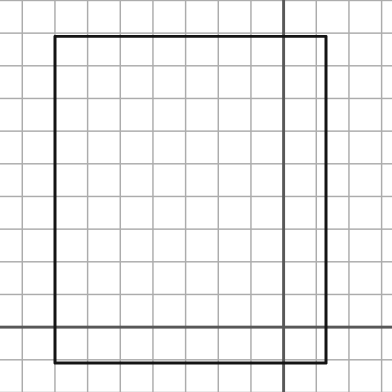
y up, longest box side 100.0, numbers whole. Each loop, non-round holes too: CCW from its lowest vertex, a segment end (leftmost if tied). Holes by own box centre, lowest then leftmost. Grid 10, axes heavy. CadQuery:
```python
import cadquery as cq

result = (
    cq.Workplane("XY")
    .moveTo(-70.0, -11.0)
    .lineTo(13.0, -11.0)
    .lineTo(13.0, 89.0)
    .lineTo(-70.0, 89.0)
    .close()
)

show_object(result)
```